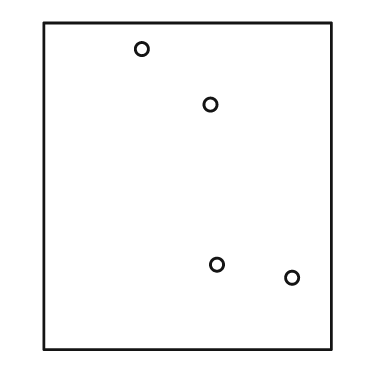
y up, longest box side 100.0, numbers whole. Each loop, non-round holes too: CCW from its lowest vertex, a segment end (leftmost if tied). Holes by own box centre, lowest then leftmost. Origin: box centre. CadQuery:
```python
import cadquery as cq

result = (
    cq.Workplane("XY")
    .moveTo(-44.0, -50.0)
    .lineTo(44.0, -50.0)
    .lineTo(44.0, 50.0)
    .lineTo(-44.0, 50.0)
    .close()
    .moveTo(32.0, -28.0)
    .circle(2.0)
    .moveTo(9.0, -24.0)
    .circle(2.0)
    .moveTo(7.0, 25.0)
    .circle(2.0)
    .moveTo(-14.0, 42.0)
    .circle(2.0)
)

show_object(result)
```